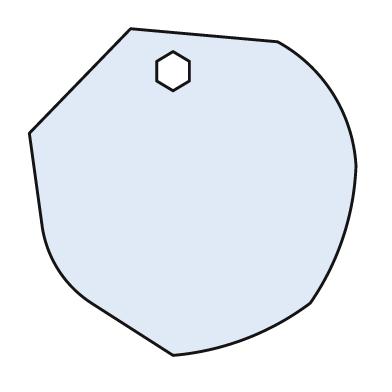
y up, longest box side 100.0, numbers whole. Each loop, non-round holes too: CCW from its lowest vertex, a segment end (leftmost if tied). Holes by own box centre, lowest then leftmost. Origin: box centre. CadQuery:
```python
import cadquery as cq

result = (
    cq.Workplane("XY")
    .moveTo(-6.0, -50.0)
    .threePointArc((16.0, -45.0), (36.0, -34.0))
    .threePointArc((46.0, -14.0), (50.0, 8.0))
    .threePointArc((43.0, 30.0), (26.0, 46.0))
    .lineTo(-19.0, 50.0)
    .lineTo(-50.0, 18.0)
    .lineTo(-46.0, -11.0)
    .threePointArc((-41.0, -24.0), (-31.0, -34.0))
    .close()
    .moveTo(-6.0, 31.0)
    .lineTo(-1.0, 34.0)
    .lineTo(-1.0, 40.0)
    .lineTo(-6.0, 43.0)
    .lineTo(-11.0, 40.0)
    .lineTo(-11.0, 34.0)
    .close()
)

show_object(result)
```